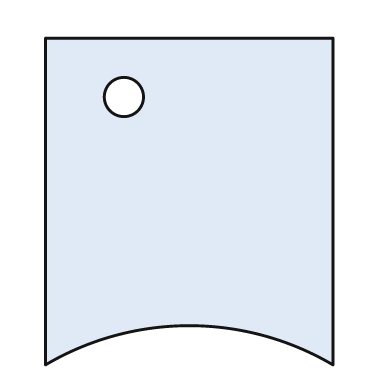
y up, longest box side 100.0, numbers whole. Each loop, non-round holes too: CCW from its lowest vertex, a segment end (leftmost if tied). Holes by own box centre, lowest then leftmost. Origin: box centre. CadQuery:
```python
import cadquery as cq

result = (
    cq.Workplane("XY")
    .moveTo(-44.0, -50.0)
    .threePointArc((0.0, -38.0), (44.0, -50.0))
    .lineTo(44.0, 50.0)
    .lineTo(-44.0, 50.0)
    .close()
    .moveTo(-20.0, 32.0)
    .circle(6.0)
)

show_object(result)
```